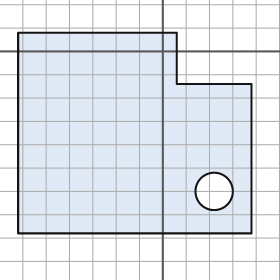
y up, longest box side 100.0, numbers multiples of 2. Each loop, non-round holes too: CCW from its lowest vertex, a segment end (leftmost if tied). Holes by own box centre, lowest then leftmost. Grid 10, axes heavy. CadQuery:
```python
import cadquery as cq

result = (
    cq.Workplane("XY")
    .moveTo(-62.0, -78.0)
    .lineTo(38.0, -78.0)
    .lineTo(38.0, -14.0)
    .lineTo(6.0, -14.0)
    .lineTo(6.0, 8.0)
    .lineTo(-62.0, 8.0)
    .close()
    .moveTo(22.0, -60.0)
    .circle(8.0)
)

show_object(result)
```